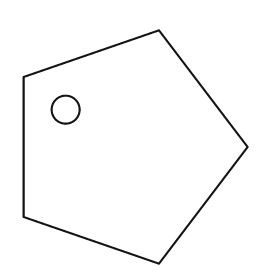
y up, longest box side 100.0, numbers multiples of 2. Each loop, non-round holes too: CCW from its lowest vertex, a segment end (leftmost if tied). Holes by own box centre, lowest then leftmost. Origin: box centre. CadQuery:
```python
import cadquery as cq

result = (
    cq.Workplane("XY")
    .moveTo(10.0, -50.0)
    .lineTo(48.0, 0.0)
    .lineTo(10.0, 50.0)
    .lineTo(-48.0, 30.0)
    .lineTo(-48.0, -30.0)
    .close()
    .moveTo(-30.0, 16.0)
    .circle(6.0)
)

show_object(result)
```